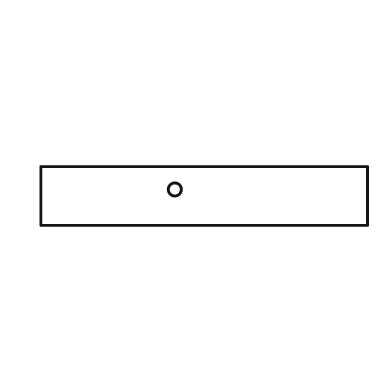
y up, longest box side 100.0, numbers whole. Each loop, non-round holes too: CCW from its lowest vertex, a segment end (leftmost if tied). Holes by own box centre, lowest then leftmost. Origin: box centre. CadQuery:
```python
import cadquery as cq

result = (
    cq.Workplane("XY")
    .moveTo(-50.0, -9.0)
    .lineTo(50.0, -9.0)
    .lineTo(50.0, 9.0)
    .lineTo(-50.0, 9.0)
    .close()
    .moveTo(-9.0, 2.0)
    .circle(2.0)
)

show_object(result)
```